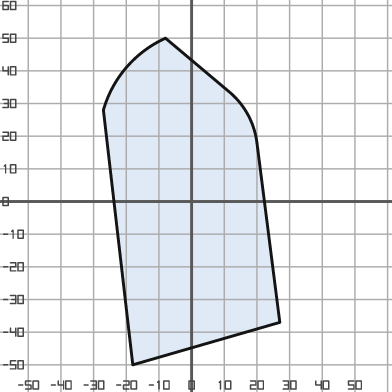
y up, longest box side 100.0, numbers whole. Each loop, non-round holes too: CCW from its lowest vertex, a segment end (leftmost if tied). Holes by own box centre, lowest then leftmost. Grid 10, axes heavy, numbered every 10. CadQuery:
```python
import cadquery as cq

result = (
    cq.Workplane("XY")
    .moveTo(-18.0, -50.0)
    .lineTo(27.0, -37.0)
    .lineTo(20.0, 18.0)
    .threePointArc((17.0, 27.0), (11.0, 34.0))
    .lineTo(-8.0, 50.0)
    .threePointArc((-20.0, 41.0), (-27.0, 28.0))
    .close()
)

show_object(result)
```